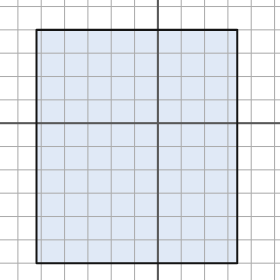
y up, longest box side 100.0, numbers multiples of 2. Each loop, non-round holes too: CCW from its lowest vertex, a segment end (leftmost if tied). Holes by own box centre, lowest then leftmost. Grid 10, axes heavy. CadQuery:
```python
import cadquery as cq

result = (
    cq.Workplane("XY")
    .moveTo(-52.0, -60.0)
    .lineTo(34.0, -60.0)
    .lineTo(34.0, 40.0)
    .lineTo(-52.0, 40.0)
    .close()
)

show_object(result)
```